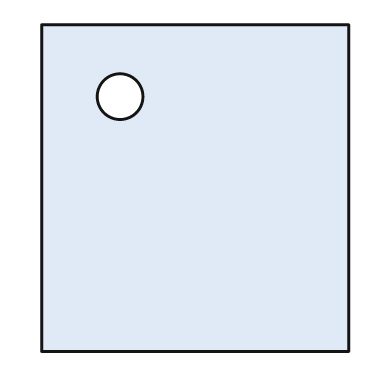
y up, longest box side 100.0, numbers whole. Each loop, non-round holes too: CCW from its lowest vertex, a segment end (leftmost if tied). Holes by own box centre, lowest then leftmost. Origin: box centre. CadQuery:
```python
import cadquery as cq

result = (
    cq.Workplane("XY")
    .moveTo(-47.0, -50.0)
    .lineTo(47.0, -50.0)
    .lineTo(47.0, 50.0)
    .lineTo(-47.0, 50.0)
    .close()
    .moveTo(-23.0, 28.0)
    .circle(7.0)
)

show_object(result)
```